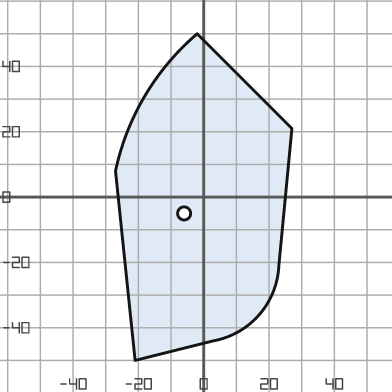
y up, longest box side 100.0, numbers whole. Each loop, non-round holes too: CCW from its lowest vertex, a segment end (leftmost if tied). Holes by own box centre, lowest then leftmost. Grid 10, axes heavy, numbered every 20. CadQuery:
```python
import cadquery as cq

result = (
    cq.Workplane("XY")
    .moveTo(-21.0, -50.0)
    .lineTo(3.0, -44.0)
    .threePointArc((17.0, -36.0), (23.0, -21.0))
    .lineTo(27.0, 21.0)
    .lineTo(-2.0, 50.0)
    .threePointArc((-18.0, 31.0), (-27.0, 8.0))
    .close()
    .moveTo(-6.0, -5.0)
    .circle(2.0)
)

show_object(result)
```